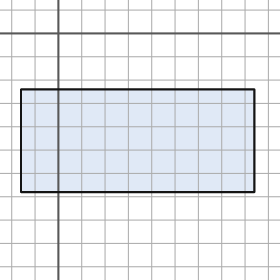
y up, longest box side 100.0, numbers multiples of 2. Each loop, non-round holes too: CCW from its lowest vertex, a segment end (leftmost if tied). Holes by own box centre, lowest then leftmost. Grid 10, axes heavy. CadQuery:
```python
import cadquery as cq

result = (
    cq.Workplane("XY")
    .moveTo(-16.0, -68.0)
    .lineTo(84.0, -68.0)
    .lineTo(84.0, -24.0)
    .lineTo(-16.0, -24.0)
    .close()
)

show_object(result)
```